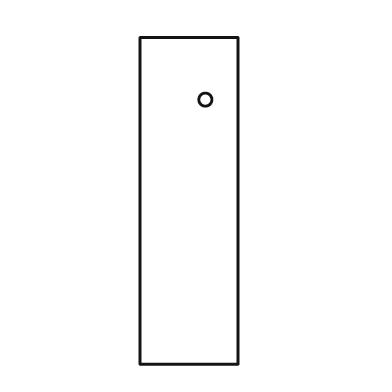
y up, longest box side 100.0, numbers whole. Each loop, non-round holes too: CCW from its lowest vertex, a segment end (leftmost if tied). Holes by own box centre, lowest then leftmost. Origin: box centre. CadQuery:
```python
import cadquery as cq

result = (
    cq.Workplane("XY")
    .moveTo(-15.0, -50.0)
    .lineTo(15.0, -50.0)
    .lineTo(15.0, 50.0)
    .lineTo(-15.0, 50.0)
    .close()
    .moveTo(5.0, 31.0)
    .circle(2.0)
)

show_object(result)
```